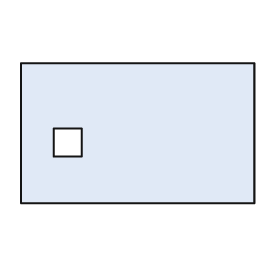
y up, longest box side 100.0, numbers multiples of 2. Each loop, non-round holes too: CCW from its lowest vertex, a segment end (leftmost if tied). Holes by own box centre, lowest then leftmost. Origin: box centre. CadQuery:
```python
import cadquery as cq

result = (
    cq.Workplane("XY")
    .moveTo(-50.0, -30.0)
    .lineTo(50.0, -30.0)
    .lineTo(50.0, 30.0)
    .lineTo(-50.0, 30.0)
    .close()
    .moveTo(-36.0, -10.0)
    .lineTo(-24.0, -10.0)
    .lineTo(-24.0, 2.0)
    .lineTo(-36.0, 2.0)
    .close()
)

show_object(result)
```